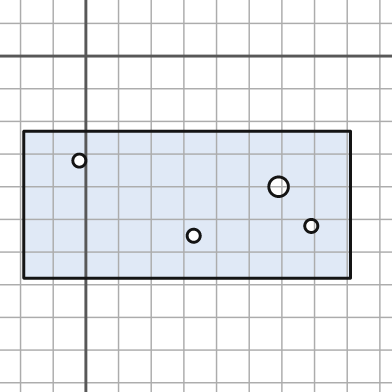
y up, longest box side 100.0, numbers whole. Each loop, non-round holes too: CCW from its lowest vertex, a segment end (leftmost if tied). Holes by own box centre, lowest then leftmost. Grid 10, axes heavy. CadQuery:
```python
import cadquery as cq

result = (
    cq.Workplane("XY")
    .moveTo(-19.0, -68.0)
    .lineTo(81.0, -68.0)
    .lineTo(81.0, -23.0)
    .lineTo(-19.0, -23.0)
    .close()
    .moveTo(33.0, -55.0)
    .circle(2.0)
    .moveTo(69.0, -52.0)
    .circle(2.0)
    .moveTo(59.0, -40.0)
    .circle(3.0)
    .moveTo(-2.0, -32.0)
    .circle(2.0)
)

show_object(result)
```